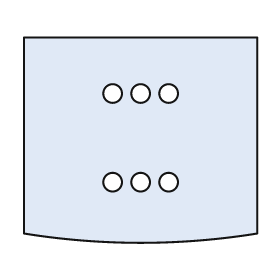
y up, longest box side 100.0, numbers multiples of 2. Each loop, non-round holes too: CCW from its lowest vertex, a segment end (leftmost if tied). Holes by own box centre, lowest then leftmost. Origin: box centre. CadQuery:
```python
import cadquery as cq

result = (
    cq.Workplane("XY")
    .moveTo(-50.0, -40.0)
    .threePointArc((0.0, -44.0), (50.0, -40.0))
    .lineTo(50.0, 44.0)
    .lineTo(-50.0, 44.0)
    .close()
    .moveTo(-12.0, -18.0)
    .circle(4.0)
    .moveTo(0.0, -18.0)
    .circle(4.0)
    .moveTo(12.0, -18.0)
    .circle(4.0)
    .moveTo(-12.0, 20.0)
    .circle(4.0)
    .moveTo(0.0, 20.0)
    .circle(4.0)
    .moveTo(12.0, 20.0)
    .circle(4.0)
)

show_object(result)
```